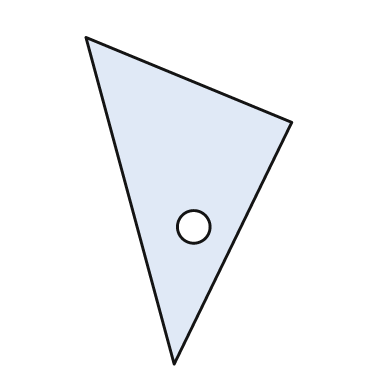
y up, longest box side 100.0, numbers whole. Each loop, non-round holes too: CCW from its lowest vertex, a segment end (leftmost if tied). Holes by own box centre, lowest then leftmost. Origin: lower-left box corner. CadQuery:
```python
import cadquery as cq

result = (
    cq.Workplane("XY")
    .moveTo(27.0, 0.0)
    .lineTo(63.0, 74.0)
    .lineTo(0.0, 100.0)
    .close()
    .moveTo(33.0, 42.0)
    .circle(5.0)
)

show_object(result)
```